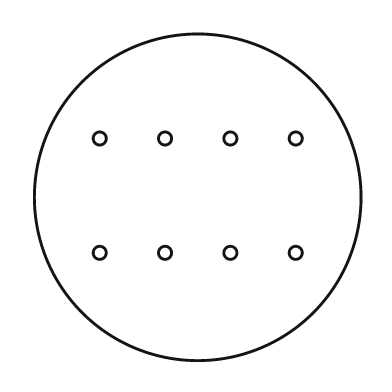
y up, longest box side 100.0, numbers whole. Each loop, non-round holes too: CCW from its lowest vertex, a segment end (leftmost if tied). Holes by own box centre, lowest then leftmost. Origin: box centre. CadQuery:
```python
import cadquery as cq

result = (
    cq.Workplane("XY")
    .moveTo(0.0, 0.0)
    .circle(50.0)
    .moveTo(-30.0, -17.0)
    .circle(2.0)
    .moveTo(-10.0, -17.0)
    .circle(2.0)
    .moveTo(10.0, -17.0)
    .circle(2.0)
    .moveTo(30.0, -17.0)
    .circle(2.0)
    .moveTo(-30.0, 18.0)
    .circle(2.0)
    .moveTo(-10.0, 18.0)
    .circle(2.0)
    .moveTo(10.0, 18.0)
    .circle(2.0)
    .moveTo(30.0, 18.0)
    .circle(2.0)
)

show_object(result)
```